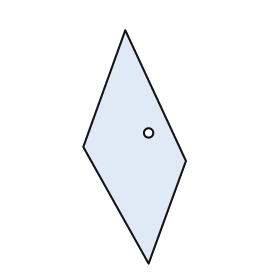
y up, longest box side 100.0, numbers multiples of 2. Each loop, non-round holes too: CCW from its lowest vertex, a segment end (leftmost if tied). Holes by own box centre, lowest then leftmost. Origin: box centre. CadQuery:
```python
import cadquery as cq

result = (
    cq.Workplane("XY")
    .moveTo(6.0, -50.0)
    .lineTo(22.0, -6.0)
    .lineTo(-4.0, 50.0)
    .lineTo(-22.0, 0.0)
    .close()
    .moveTo(6.0, 6.0)
    .circle(2.0)
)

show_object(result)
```